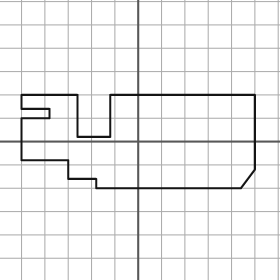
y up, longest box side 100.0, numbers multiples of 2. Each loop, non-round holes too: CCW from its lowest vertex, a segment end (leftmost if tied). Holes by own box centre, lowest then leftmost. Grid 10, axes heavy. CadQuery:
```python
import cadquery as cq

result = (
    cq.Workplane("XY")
    .moveTo(-18.0, -20.0)
    .lineTo(44.0, -20.0)
    .lineTo(50.0, -12.0)
    .lineTo(50.0, 20.0)
    .lineTo(-12.0, 20.0)
    .lineTo(-12.0, 2.0)
    .lineTo(-26.0, 2.0)
    .lineTo(-26.0, 20.0)
    .lineTo(-50.0, 20.0)
    .lineTo(-50.0, 14.0)
    .lineTo(-38.0, 14.0)
    .lineTo(-38.0, 10.0)
    .lineTo(-50.0, 10.0)
    .lineTo(-50.0, -8.0)
    .lineTo(-30.0, -8.0)
    .lineTo(-30.0, -16.0)
    .lineTo(-18.0, -16.0)
    .close()
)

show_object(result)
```